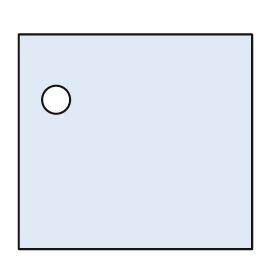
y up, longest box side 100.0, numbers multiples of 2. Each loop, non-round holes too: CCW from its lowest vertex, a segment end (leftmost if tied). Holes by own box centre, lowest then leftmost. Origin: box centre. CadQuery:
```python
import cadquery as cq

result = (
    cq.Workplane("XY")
    .moveTo(-50.0, -46.0)
    .lineTo(50.0, -46.0)
    .lineTo(50.0, 46.0)
    .lineTo(-50.0, 46.0)
    .close()
    .moveTo(-34.0, 18.0)
    .circle(6.0)
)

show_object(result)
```